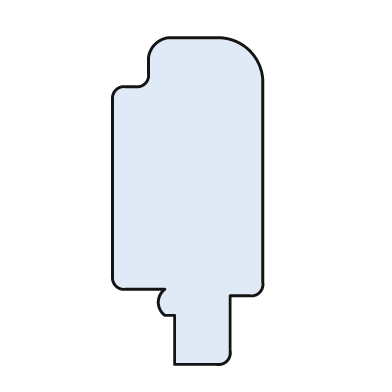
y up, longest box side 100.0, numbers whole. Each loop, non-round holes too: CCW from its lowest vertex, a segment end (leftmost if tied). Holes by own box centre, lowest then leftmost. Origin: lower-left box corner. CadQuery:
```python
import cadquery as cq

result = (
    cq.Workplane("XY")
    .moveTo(19.0, 0.0)
    .lineTo(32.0, 0.0)
    .threePointArc((35.0, 1.0), (36.0, 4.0))
    .lineTo(36.0, 21.0)
    .lineTo(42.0, 21.0)
    .threePointArc((45.0, 22.0), (46.0, 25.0))
    .lineTo(46.0, 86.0)
    .threePointArc((42.0, 96.0), (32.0, 100.0))
    .lineTo(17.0, 100.0)
    .threePointArc((13.0, 98.0), (11.0, 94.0))
    .lineTo(11.0, 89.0)
    .threePointArc((10.0, 86.0), (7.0, 85.0))
    .lineTo(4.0, 85.0)
    .threePointArc((1.0, 84.0), (0.0, 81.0))
    .lineTo(0.0, 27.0)
    .threePointArc((1.0, 24.0), (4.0, 23.0))
    .lineTo(16.0, 23.0)
    .threePointArc((14.0, 19.0), (16.0, 15.0))
    .lineTo(19.0, 15.0)
    .close()
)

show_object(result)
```